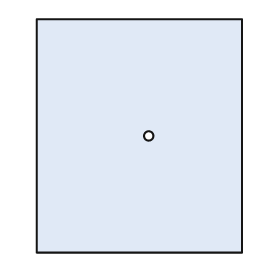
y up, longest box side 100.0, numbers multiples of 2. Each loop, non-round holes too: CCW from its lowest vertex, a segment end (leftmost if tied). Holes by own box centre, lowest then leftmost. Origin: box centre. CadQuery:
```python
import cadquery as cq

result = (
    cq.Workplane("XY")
    .moveTo(-44.0, -50.0)
    .lineTo(44.0, -50.0)
    .lineTo(44.0, 50.0)
    .lineTo(-44.0, 50.0)
    .close()
    .moveTo(4.0, 0.0)
    .circle(2.0)
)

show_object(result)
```